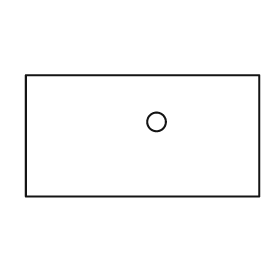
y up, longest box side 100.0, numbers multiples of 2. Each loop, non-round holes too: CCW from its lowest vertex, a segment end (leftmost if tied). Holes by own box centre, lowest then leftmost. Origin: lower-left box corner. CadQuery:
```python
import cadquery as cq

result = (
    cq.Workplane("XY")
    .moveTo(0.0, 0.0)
    .lineTo(100.0, 0.0)
    .lineTo(100.0, 52.0)
    .lineTo(0.0, 52.0)
    .close()
    .moveTo(56.0, 32.0)
    .circle(4.0)
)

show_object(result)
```